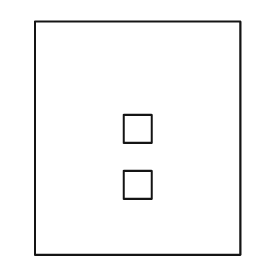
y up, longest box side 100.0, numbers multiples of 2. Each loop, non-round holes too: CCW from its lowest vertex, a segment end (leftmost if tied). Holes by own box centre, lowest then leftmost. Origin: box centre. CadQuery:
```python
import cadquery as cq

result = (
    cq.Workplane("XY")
    .moveTo(-44.0, -50.0)
    .lineTo(44.0, -50.0)
    .lineTo(44.0, 50.0)
    .lineTo(-44.0, 50.0)
    .close()
    .moveTo(-6.0, -26.0)
    .lineTo(6.0, -26.0)
    .lineTo(6.0, -14.0)
    .lineTo(-6.0, -14.0)
    .close()
    .moveTo(-6.0, -2.0)
    .lineTo(6.0, -2.0)
    .lineTo(6.0, 10.0)
    .lineTo(-6.0, 10.0)
    .close()
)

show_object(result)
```